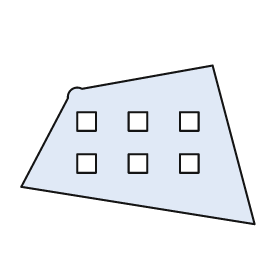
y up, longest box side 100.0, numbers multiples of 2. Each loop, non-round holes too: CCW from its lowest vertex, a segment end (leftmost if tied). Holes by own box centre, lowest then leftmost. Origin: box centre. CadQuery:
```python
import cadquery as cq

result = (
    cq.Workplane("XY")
    .moveTo(50.0, -34.0)
    .lineTo(32.0, 34.0)
    .lineTo(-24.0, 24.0)
    .threePointArc((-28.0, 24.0), (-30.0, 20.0))
    .lineTo(-50.0, -18.0)
    .close()
    .moveTo(-26.0, -12.0)
    .lineTo(-18.0, -12.0)
    .lineTo(-18.0, -4.0)
    .lineTo(-26.0, -4.0)
    .close()
    .moveTo(-4.0, -12.0)
    .lineTo(4.0, -12.0)
    .lineTo(4.0, -4.0)
    .lineTo(-4.0, -4.0)
    .close()
    .moveTo(18.0, -12.0)
    .lineTo(26.0, -12.0)
    .lineTo(26.0, -4.0)
    .lineTo(18.0, -4.0)
    .close()
    .moveTo(-26.0, 6.0)
    .lineTo(-18.0, 6.0)
    .lineTo(-18.0, 14.0)
    .lineTo(-26.0, 14.0)
    .close()
    .moveTo(-4.0, 6.0)
    .lineTo(4.0, 6.0)
    .lineTo(4.0, 14.0)
    .lineTo(-4.0, 14.0)
    .close()
    .moveTo(18.0, 6.0)
    .lineTo(26.0, 6.0)
    .lineTo(26.0, 14.0)
    .lineTo(18.0, 14.0)
    .close()
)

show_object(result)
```